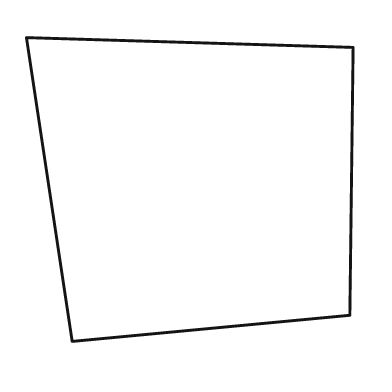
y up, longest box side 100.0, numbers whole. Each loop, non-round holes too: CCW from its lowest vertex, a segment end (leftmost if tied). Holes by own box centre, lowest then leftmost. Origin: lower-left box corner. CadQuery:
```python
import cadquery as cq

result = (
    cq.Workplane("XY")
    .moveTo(14.0, 0.0)
    .lineTo(99.0, 8.0)
    .lineTo(100.0, 90.0)
    .lineTo(0.0, 93.0)
    .close()
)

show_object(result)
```